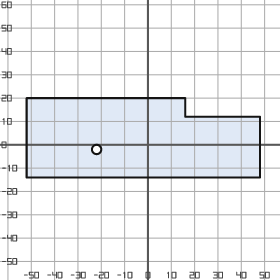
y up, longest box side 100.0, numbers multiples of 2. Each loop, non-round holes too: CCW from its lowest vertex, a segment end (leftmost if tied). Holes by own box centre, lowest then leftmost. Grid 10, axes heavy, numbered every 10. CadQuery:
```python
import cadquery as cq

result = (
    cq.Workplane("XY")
    .moveTo(-52.0, -14.0)
    .lineTo(48.0, -14.0)
    .lineTo(48.0, 12.0)
    .lineTo(16.0, 12.0)
    .lineTo(16.0, 20.0)
    .lineTo(-52.0, 20.0)
    .close()
    .moveTo(-22.0, -2.0)
    .circle(2.0)
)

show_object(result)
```